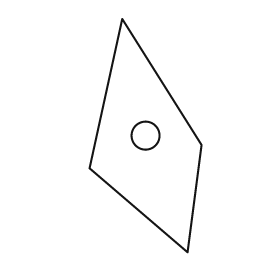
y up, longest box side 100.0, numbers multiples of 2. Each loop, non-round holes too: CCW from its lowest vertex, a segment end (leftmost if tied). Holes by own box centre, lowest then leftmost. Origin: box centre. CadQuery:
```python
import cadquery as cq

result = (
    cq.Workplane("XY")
    .moveTo(18.0, -50.0)
    .lineTo(24.0, -4.0)
    .lineTo(-10.0, 50.0)
    .lineTo(-24.0, -14.0)
    .close()
    .moveTo(0.0, 0.0)
    .circle(6.0)
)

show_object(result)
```